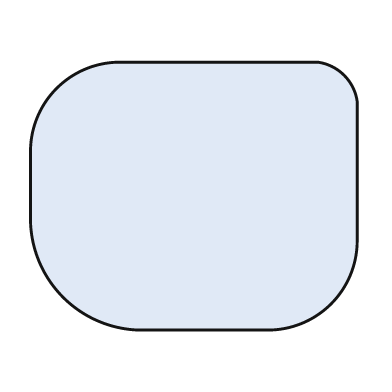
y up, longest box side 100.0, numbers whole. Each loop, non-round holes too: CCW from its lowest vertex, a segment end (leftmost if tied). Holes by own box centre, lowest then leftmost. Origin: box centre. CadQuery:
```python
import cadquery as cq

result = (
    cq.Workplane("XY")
    .moveTo(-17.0, -41.0)
    .lineTo(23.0, -41.0)
    .threePointArc((42.0, -33.0), (50.0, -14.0))
    .lineTo(50.0, 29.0)
    .threePointArc((46.0, 37.0), (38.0, 41.0))
    .lineTo(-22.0, 41.0)
    .threePointArc((-42.0, 33.0), (-50.0, 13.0))
    .lineTo(-50.0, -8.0)
    .threePointArc((-40.0, -31.0), (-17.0, -41.0))
    .close()
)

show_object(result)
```